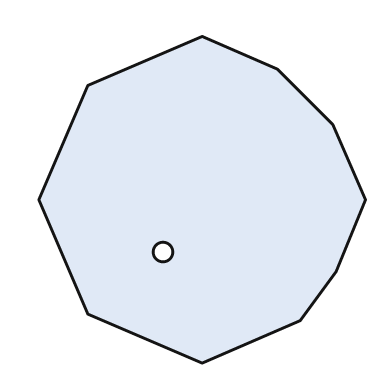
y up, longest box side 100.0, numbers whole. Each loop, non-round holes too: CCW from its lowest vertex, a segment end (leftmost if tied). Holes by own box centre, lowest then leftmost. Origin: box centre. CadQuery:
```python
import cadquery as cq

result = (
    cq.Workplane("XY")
    .moveTo(0.0, -50.0)
    .lineTo(30.0, -37.0)
    .lineTo(41.0, -22.0)
    .lineTo(50.0, 0.0)
    .lineTo(40.0, 23.0)
    .lineTo(23.0, 40.0)
    .lineTo(0.0, 50.0)
    .lineTo(-35.0, 35.0)
    .lineTo(-50.0, 0.0)
    .lineTo(-35.0, -35.0)
    .close()
    .moveTo(-12.0, -16.0)
    .circle(3.0)
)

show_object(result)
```